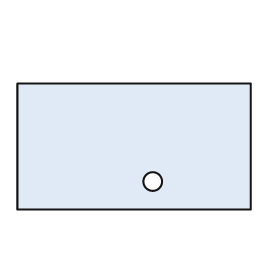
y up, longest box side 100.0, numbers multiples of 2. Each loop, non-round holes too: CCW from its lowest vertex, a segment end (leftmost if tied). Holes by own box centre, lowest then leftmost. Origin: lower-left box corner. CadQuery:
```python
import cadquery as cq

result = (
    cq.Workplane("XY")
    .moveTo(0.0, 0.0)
    .lineTo(100.0, 0.0)
    .lineTo(100.0, 54.0)
    .lineTo(0.0, 54.0)
    .close()
    .moveTo(58.0, 12.0)
    .circle(4.0)
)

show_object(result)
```